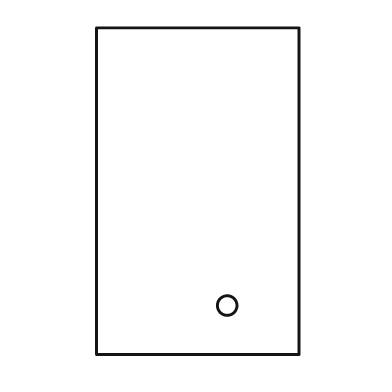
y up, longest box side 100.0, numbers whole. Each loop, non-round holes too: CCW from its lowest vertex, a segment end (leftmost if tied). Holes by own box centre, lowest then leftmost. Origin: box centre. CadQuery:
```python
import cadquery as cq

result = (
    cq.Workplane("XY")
    .moveTo(-31.0, -50.0)
    .lineTo(31.0, -50.0)
    .lineTo(31.0, 50.0)
    .lineTo(-31.0, 50.0)
    .close()
    .moveTo(9.0, -35.0)
    .circle(3.0)
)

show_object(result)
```